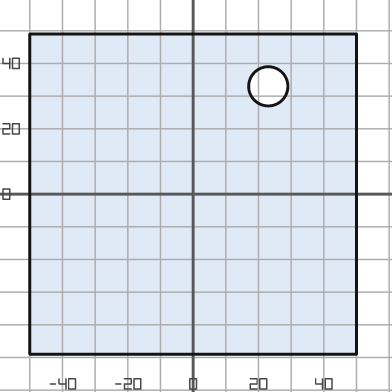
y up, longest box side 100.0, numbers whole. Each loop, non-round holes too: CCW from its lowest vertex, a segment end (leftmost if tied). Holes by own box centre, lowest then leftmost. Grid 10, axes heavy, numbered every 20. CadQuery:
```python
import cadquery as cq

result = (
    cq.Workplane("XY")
    .moveTo(-50.0, -49.0)
    .lineTo(50.0, -49.0)
    .lineTo(50.0, 49.0)
    .lineTo(-50.0, 49.0)
    .close()
    .moveTo(23.0, 33.0)
    .circle(6.0)
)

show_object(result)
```